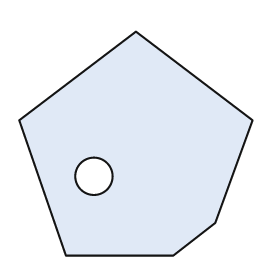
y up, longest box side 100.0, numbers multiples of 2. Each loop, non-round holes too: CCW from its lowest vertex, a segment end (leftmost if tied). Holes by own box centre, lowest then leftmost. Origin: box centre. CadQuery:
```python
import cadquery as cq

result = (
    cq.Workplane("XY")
    .moveTo(-30.0, -48.0)
    .lineTo(16.0, -48.0)
    .lineTo(34.0, -34.0)
    .lineTo(50.0, 10.0)
    .lineTo(0.0, 48.0)
    .lineTo(-50.0, 10.0)
    .close()
    .moveTo(-18.0, -14.0)
    .circle(8.0)
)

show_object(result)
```